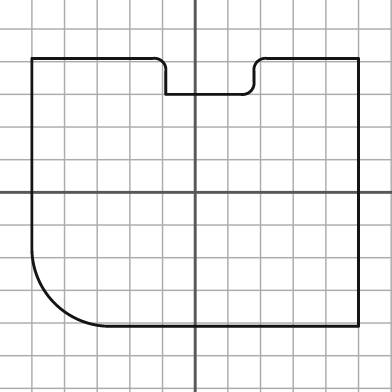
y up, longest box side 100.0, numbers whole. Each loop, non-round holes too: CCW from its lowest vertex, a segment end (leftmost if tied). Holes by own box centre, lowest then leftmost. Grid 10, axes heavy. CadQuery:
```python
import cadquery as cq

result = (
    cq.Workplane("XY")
    .moveTo(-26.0, -41.0)
    .lineTo(50.0, -41.0)
    .lineTo(50.0, 41.0)
    .lineTo(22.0, 41.0)
    .threePointArc((19.0, 40.0), (18.0, 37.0))
    .lineTo(18.0, 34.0)
    .threePointArc((17.0, 31.0), (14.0, 30.0))
    .lineTo(-9.0, 30.0)
    .lineTo(-9.0, 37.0)
    .threePointArc((-10.0, 40.0), (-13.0, 41.0))
    .lineTo(-50.0, 41.0)
    .lineTo(-50.0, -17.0)
    .threePointArc((-43.0, -34.0), (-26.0, -41.0))
    .close()
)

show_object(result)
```